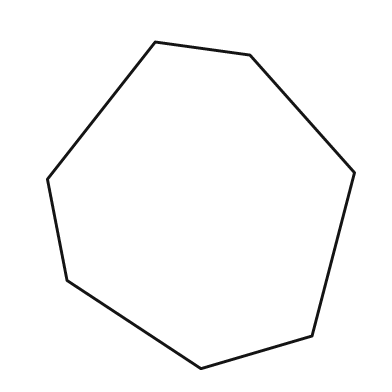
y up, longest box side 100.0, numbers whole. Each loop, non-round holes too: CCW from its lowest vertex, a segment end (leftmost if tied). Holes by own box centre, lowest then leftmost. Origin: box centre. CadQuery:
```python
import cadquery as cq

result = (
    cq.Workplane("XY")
    .moveTo(0.0, -50.0)
    .lineTo(34.0, -40.0)
    .lineTo(47.0, 10.0)
    .lineTo(15.0, 46.0)
    .lineTo(-14.0, 50.0)
    .lineTo(-47.0, 8.0)
    .lineTo(-41.0, -23.0)
    .close()
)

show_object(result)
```